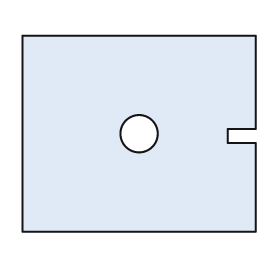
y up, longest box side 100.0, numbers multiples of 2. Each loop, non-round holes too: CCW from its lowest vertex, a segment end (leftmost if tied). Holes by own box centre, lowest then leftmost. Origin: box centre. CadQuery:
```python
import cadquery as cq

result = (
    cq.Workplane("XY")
    .moveTo(-50.0, -42.0)
    .lineTo(50.0, -42.0)
    .lineTo(50.0, -4.0)
    .lineTo(38.0, -4.0)
    .lineTo(38.0, 2.0)
    .lineTo(50.0, 2.0)
    .lineTo(50.0, 42.0)
    .lineTo(-50.0, 42.0)
    .close()
    .moveTo(0.0, 0.0)
    .circle(8.0)
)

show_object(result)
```